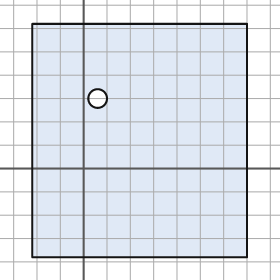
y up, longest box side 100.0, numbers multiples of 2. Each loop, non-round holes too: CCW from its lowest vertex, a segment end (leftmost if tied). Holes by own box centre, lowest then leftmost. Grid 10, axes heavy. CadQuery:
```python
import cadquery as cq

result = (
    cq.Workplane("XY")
    .moveTo(-22.0, -38.0)
    .lineTo(70.0, -38.0)
    .lineTo(70.0, 62.0)
    .lineTo(-22.0, 62.0)
    .close()
    .moveTo(6.0, 30.0)
    .circle(4.0)
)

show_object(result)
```